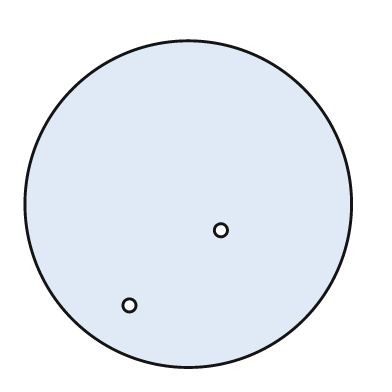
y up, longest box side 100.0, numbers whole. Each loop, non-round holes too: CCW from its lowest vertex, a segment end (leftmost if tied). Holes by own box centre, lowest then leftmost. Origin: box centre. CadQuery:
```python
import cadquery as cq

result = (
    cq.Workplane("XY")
    .moveTo(0.0, 0.0)
    .circle(50.0)
    .moveTo(-18.0, -31.0)
    .circle(2.0)
    .moveTo(10.0, -8.0)
    .circle(2.0)
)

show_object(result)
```